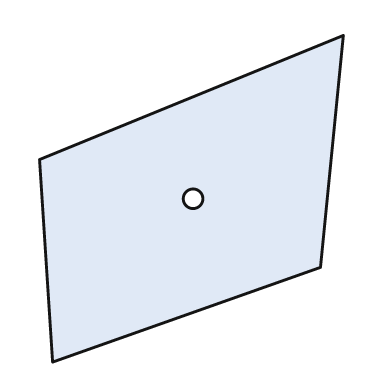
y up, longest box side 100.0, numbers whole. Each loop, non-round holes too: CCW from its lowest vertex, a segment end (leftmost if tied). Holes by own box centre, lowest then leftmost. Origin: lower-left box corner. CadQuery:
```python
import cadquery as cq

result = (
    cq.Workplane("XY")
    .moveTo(4.0, 0.0)
    .lineTo(86.0, 29.0)
    .lineTo(93.0, 100.0)
    .lineTo(0.0, 62.0)
    .close()
    .moveTo(47.0, 50.0)
    .circle(3.0)
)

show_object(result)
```